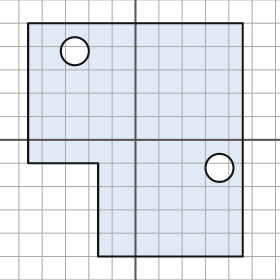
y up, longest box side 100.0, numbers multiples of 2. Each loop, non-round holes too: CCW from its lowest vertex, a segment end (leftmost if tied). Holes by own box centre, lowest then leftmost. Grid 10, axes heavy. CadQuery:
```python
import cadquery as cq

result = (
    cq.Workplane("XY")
    .moveTo(-16.0, -50.0)
    .lineTo(46.0, -50.0)
    .lineTo(46.0, 50.0)
    .lineTo(-46.0, 50.0)
    .lineTo(-46.0, -10.0)
    .lineTo(-16.0, -10.0)
    .close()
    .moveTo(36.0, -12.0)
    .circle(6.0)
    .moveTo(-26.0, 38.0)
    .circle(6.0)
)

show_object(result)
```